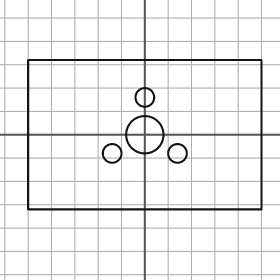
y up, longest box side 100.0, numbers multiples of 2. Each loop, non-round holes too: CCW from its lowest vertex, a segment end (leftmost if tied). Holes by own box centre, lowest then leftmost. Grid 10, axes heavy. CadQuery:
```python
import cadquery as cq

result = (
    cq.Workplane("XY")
    .moveTo(-50.0, -32.0)
    .lineTo(50.0, -32.0)
    .lineTo(50.0, 32.0)
    .lineTo(-50.0, 32.0)
    .close()
    .moveTo(-14.0, -8.0)
    .circle(4.0)
    .moveTo(14.0, -8.0)
    .circle(4.0)
    .moveTo(0.0, 0.0)
    .circle(8.0)
    .moveTo(0.0, 16.0)
    .circle(4.0)
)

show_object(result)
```